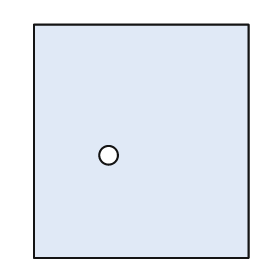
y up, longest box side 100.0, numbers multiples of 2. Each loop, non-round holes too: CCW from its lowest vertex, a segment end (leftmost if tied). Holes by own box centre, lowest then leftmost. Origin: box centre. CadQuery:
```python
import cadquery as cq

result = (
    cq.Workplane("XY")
    .moveTo(-46.0, -50.0)
    .lineTo(46.0, -50.0)
    .lineTo(46.0, 50.0)
    .lineTo(-46.0, 50.0)
    .close()
    .moveTo(-14.0, -6.0)
    .circle(4.0)
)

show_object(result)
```